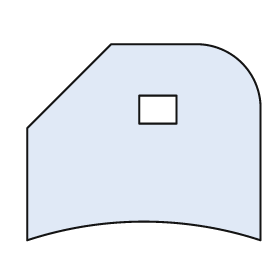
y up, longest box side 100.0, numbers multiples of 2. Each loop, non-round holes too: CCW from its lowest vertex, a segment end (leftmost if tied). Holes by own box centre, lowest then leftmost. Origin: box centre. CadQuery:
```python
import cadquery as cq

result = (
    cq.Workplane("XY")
    .moveTo(-50.0, -42.0)
    .threePointArc((0.0, -34.0), (50.0, -42.0))
    .lineTo(50.0, 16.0)
    .threePointArc((42.0, 34.0), (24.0, 42.0))
    .lineTo(-14.0, 42.0)
    .lineTo(-50.0, 6.0)
    .close()
    .moveTo(-2.0, 8.0)
    .lineTo(14.0, 8.0)
    .lineTo(14.0, 20.0)
    .lineTo(-2.0, 20.0)
    .close()
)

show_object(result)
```